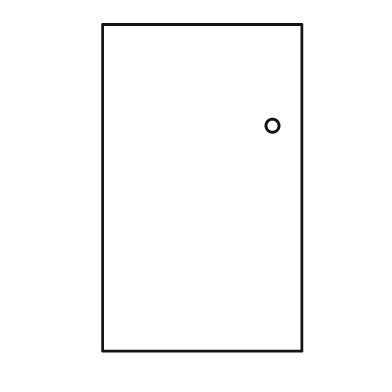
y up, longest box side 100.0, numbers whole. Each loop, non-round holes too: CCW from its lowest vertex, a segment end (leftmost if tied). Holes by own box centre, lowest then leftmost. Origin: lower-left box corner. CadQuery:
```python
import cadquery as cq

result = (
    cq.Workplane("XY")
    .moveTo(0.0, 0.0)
    .lineTo(61.0, 0.0)
    .lineTo(61.0, 100.0)
    .lineTo(0.0, 100.0)
    .close()
    .moveTo(52.0, 69.0)
    .circle(2.0)
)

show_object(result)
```